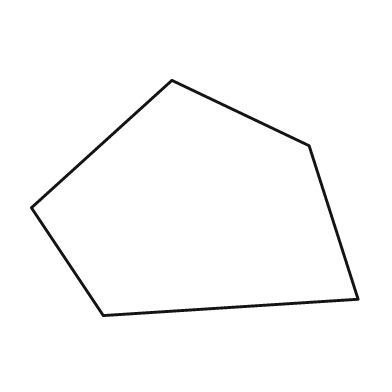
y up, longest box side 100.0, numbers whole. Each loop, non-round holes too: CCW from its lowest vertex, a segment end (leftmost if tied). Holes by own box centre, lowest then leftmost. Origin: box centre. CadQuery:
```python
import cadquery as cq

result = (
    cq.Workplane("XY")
    .moveTo(-28.0, -36.0)
    .lineTo(50.0, -31.0)
    .lineTo(35.0, 16.0)
    .lineTo(-7.0, 36.0)
    .lineTo(-50.0, -3.0)
    .close()
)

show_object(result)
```